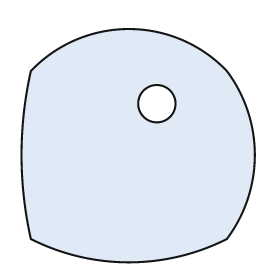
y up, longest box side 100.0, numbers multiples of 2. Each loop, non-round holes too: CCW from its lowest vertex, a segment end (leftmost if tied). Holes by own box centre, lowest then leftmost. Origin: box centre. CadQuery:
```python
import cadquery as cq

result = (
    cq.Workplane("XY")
    .moveTo(-46.0, -40.0)
    .threePointArc((-4.0, -50.0), (38.0, -40.0))
    .threePointArc((50.0, -4.0), (38.0, 32.0))
    .threePointArc((-4.0, 50.0), (-46.0, 32.0))
    .threePointArc((-50.0, -4.0), (-46.0, -40.0))
    .close()
    .moveTo(8.0, 18.0)
    .circle(8.0)
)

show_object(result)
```